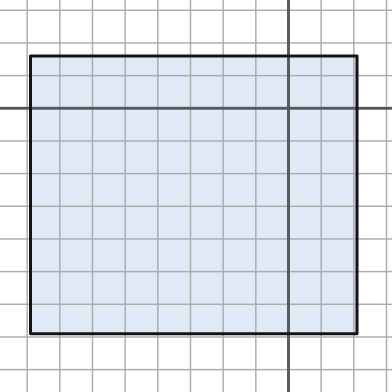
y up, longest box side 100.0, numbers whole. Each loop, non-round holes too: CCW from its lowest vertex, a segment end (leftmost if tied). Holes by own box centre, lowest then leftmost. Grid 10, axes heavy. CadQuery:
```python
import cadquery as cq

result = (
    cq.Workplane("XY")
    .moveTo(-79.0, -69.0)
    .lineTo(21.0, -69.0)
    .lineTo(21.0, 16.0)
    .lineTo(-79.0, 16.0)
    .close()
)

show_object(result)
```